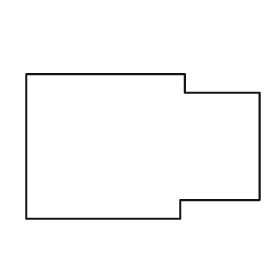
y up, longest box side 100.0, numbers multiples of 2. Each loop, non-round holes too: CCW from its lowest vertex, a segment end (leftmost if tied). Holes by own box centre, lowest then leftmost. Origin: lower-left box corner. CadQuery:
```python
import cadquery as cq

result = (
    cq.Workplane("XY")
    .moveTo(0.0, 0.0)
    .lineTo(66.0, 0.0)
    .lineTo(66.0, 8.0)
    .lineTo(100.0, 8.0)
    .lineTo(100.0, 54.0)
    .lineTo(68.0, 54.0)
    .lineTo(68.0, 62.0)
    .lineTo(0.0, 62.0)
    .close()
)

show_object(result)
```